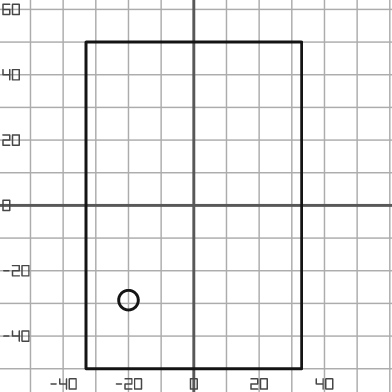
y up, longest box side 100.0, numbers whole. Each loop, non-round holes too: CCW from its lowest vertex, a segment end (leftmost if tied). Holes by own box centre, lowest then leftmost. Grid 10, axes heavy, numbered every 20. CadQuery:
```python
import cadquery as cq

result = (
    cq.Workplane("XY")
    .moveTo(-33.0, -50.0)
    .lineTo(33.0, -50.0)
    .lineTo(33.0, 50.0)
    .lineTo(-33.0, 50.0)
    .close()
    .moveTo(-20.0, -29.0)
    .circle(3.0)
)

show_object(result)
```